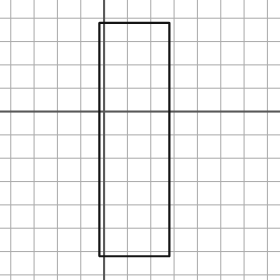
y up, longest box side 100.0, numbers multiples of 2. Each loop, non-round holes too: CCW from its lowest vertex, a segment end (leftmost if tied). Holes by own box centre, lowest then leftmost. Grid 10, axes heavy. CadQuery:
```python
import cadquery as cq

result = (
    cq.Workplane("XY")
    .moveTo(-2.0, -62.0)
    .lineTo(28.0, -62.0)
    .lineTo(28.0, 38.0)
    .lineTo(-2.0, 38.0)
    .close()
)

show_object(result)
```